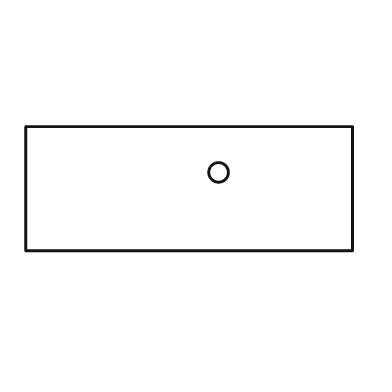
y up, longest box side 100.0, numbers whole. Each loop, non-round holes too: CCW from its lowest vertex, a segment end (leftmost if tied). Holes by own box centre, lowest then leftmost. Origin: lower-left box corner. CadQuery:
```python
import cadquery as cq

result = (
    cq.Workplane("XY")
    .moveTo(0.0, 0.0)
    .lineTo(100.0, 0.0)
    .lineTo(100.0, 38.0)
    .lineTo(0.0, 38.0)
    .close()
    .moveTo(59.0, 24.0)
    .circle(3.0)
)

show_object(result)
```